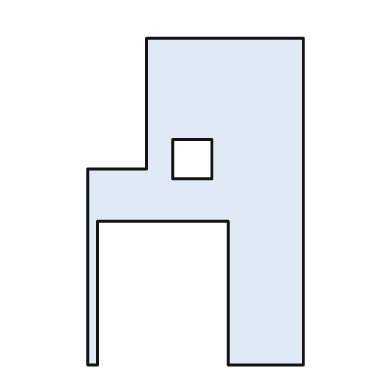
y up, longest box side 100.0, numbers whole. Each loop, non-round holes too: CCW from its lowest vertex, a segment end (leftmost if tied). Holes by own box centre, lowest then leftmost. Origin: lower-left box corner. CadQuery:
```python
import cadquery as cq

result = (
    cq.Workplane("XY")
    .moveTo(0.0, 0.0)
    .lineTo(3.0, 0.0)
    .lineTo(3.0, 44.0)
    .lineTo(43.0, 44.0)
    .lineTo(43.0, 0.0)
    .lineTo(66.0, 0.0)
    .lineTo(66.0, 100.0)
    .lineTo(18.0, 100.0)
    .lineTo(18.0, 60.0)
    .lineTo(0.0, 60.0)
    .close()
    .moveTo(26.0, 57.0)
    .lineTo(38.0, 57.0)
    .lineTo(38.0, 69.0)
    .lineTo(26.0, 69.0)
    .close()
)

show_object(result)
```